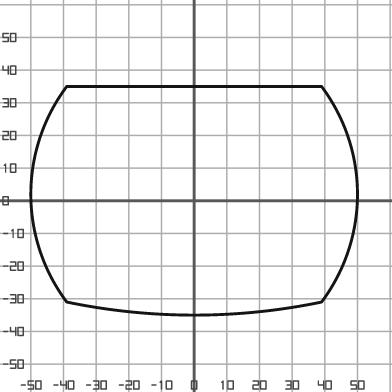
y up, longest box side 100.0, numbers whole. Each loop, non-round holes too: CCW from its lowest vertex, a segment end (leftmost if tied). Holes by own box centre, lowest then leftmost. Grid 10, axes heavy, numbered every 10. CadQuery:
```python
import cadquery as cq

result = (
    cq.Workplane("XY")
    .moveTo(-39.0, -31.0)
    .threePointArc((0.0, -35.0), (39.0, -31.0))
    .threePointArc((50.0, 2.0), (39.0, 35.0))
    .lineTo(-39.0, 35.0)
    .threePointArc((-50.0, 2.0), (-39.0, -31.0))
    .close()
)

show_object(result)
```